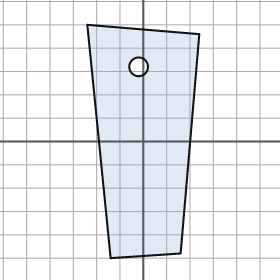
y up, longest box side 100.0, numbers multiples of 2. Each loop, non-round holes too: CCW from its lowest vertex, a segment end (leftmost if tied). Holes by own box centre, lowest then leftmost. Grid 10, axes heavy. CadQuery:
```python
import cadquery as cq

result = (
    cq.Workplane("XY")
    .moveTo(-14.0, -50.0)
    .lineTo(16.0, -48.0)
    .lineTo(24.0, 46.0)
    .lineTo(-24.0, 50.0)
    .close()
    .moveTo(-2.0, 32.0)
    .circle(4.0)
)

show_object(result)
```